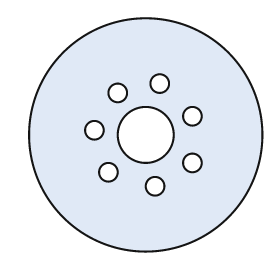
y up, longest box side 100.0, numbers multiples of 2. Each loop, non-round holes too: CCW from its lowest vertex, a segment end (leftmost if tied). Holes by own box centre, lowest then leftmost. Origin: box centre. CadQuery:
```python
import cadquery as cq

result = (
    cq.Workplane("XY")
    .moveTo(0.0, 0.0)
    .circle(50.0)
    .moveTo(4.0, -22.0)
    .circle(4.0)
    .moveTo(-16.0, -16.0)
    .circle(4.0)
    .moveTo(20.0, -12.0)
    .circle(4.0)
    .moveTo(0.0, 0.0)
    .circle(12.0)
    .moveTo(-22.0, 2.0)
    .circle(4.0)
    .moveTo(20.0, 8.0)
    .circle(4.0)
    .moveTo(-12.0, 18.0)
    .circle(4.0)
    .moveTo(6.0, 22.0)
    .circle(4.0)
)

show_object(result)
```